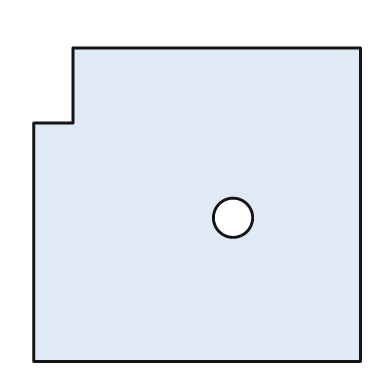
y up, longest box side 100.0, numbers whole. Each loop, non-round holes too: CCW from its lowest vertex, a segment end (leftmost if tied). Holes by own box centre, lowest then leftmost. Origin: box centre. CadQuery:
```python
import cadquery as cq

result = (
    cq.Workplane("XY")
    .moveTo(-50.0, -48.0)
    .lineTo(50.0, -48.0)
    .lineTo(50.0, 48.0)
    .lineTo(-38.0, 48.0)
    .lineTo(-38.0, 25.0)
    .lineTo(-50.0, 25.0)
    .close()
    .moveTo(11.0, -4.0)
    .circle(6.0)
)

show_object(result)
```